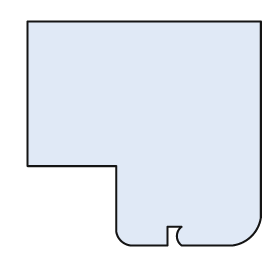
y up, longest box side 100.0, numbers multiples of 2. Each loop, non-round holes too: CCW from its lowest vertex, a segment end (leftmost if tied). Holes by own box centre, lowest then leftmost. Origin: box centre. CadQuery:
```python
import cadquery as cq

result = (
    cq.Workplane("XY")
    .moveTo(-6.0, -48.0)
    .lineTo(10.0, -48.0)
    .lineTo(10.0, -40.0)
    .lineTo(16.0, -40.0)
    .threePointArc((14.0, -44.0), (16.0, -48.0))
    .lineTo(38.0, -48.0)
    .threePointArc((46.0, -44.0), (50.0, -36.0))
    .lineTo(50.0, 48.0)
    .lineTo(-50.0, 48.0)
    .lineTo(-50.0, -14.0)
    .lineTo(-12.0, -14.0)
    .lineTo(-12.0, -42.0)
    .threePointArc((-10.0, -46.0), (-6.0, -48.0))
    .close()
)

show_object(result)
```